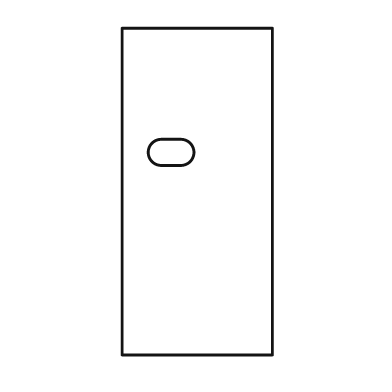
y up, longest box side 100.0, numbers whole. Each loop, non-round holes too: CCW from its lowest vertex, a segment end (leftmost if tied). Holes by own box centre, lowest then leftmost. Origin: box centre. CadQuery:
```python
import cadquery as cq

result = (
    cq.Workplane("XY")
    .moveTo(-23.0, -50.0)
    .lineTo(23.0, -50.0)
    .lineTo(23.0, 50.0)
    .lineTo(-23.0, 50.0)
    .close()
    .moveTo(-11.0, 8.0)
    .lineTo(-5.0, 8.0)
    .threePointArc((-1.0, 12.0), (-5.0, 16.0))
    .lineTo(-11.0, 16.0)
    .threePointArc((-15.0, 12.0), (-11.0, 8.0))
    .close()
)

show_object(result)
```